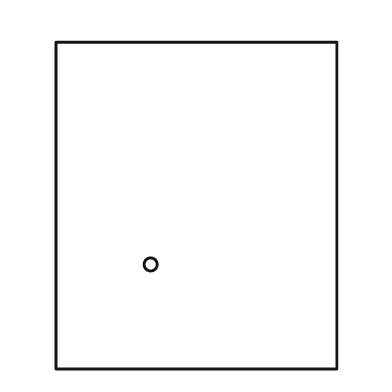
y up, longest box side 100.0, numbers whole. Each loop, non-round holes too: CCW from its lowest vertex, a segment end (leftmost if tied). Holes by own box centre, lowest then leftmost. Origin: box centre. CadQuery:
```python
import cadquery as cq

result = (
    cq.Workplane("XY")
    .moveTo(-43.0, -50.0)
    .lineTo(43.0, -50.0)
    .lineTo(43.0, 50.0)
    .lineTo(-43.0, 50.0)
    .close()
    .moveTo(-14.0, -18.0)
    .circle(2.0)
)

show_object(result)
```